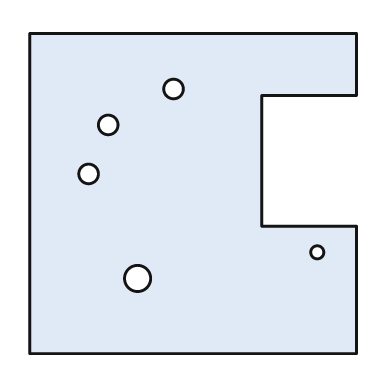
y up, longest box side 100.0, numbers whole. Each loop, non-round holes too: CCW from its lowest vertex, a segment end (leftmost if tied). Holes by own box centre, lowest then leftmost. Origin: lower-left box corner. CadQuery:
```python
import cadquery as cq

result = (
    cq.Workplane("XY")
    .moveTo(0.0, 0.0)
    .lineTo(100.0, 0.0)
    .lineTo(100.0, 39.0)
    .lineTo(71.0, 39.0)
    .lineTo(71.0, 79.0)
    .lineTo(100.0, 79.0)
    .lineTo(100.0, 98.0)
    .lineTo(0.0, 98.0)
    .close()
    .moveTo(33.0, 23.0)
    .circle(4.0)
    .moveTo(88.0, 31.0)
    .circle(2.0)
    .moveTo(18.0, 55.0)
    .circle(3.0)
    .moveTo(24.0, 70.0)
    .circle(3.0)
    .moveTo(44.0, 81.0)
    .circle(3.0)
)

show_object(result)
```